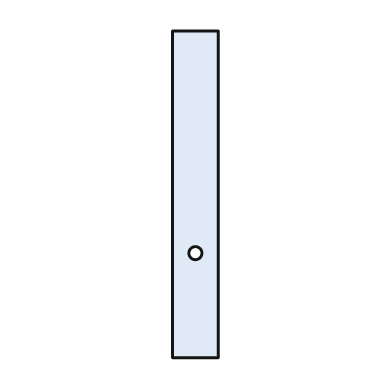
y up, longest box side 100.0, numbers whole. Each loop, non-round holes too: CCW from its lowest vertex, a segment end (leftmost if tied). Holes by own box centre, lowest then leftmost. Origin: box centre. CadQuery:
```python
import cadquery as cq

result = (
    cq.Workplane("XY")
    .moveTo(-7.0, -50.0)
    .lineTo(7.0, -50.0)
    .lineTo(7.0, 50.0)
    .lineTo(-7.0, 50.0)
    .close()
    .moveTo(0.0, -18.0)
    .circle(2.0)
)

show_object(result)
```